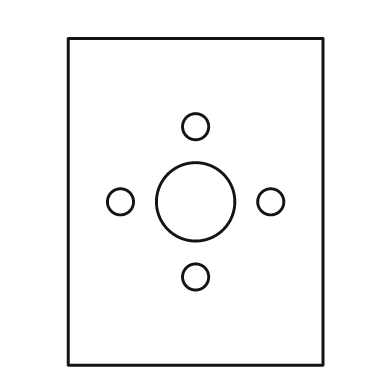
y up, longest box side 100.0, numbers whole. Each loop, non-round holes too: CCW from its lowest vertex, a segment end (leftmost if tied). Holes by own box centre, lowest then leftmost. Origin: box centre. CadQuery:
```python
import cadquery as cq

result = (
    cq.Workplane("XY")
    .moveTo(-39.0, -50.0)
    .lineTo(39.0, -50.0)
    .lineTo(39.0, 50.0)
    .lineTo(-39.0, 50.0)
    .close()
    .moveTo(0.0, -23.0)
    .circle(4.0)
    .moveTo(-23.0, 0.0)
    .circle(4.0)
    .moveTo(0.0, 0.0)
    .circle(12.0)
    .moveTo(23.0, 0.0)
    .circle(4.0)
    .moveTo(0.0, 23.0)
    .circle(4.0)
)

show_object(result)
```